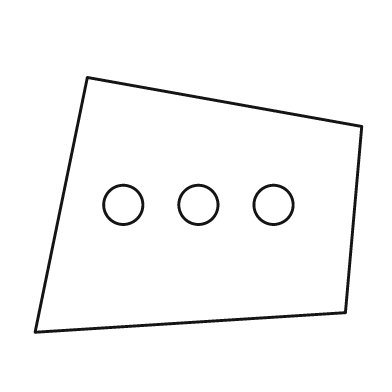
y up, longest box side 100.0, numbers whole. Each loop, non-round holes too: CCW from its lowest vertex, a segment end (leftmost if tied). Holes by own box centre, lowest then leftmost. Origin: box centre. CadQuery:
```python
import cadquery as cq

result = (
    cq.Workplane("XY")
    .moveTo(-50.0, -39.0)
    .lineTo(45.0, -33.0)
    .lineTo(50.0, 24.0)
    .lineTo(-34.0, 39.0)
    .close()
    .moveTo(-23.0, 0.0)
    .circle(6.0)
    .moveTo(0.0, 0.0)
    .circle(6.0)
    .moveTo(23.0, 0.0)
    .circle(6.0)
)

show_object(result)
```